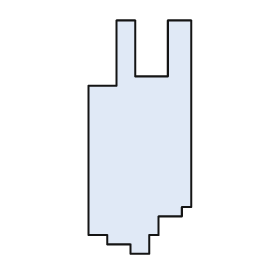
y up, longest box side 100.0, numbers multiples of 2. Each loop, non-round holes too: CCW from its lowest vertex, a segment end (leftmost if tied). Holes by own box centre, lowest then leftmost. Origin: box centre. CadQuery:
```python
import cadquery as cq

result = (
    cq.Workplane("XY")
    .moveTo(-4.0, -50.0)
    .lineTo(4.0, -50.0)
    .lineTo(4.0, -42.0)
    .lineTo(8.0, -42.0)
    .lineTo(8.0, -34.0)
    .lineTo(18.0, -34.0)
    .lineTo(18.0, -30.0)
    .lineTo(22.0, -30.0)
    .lineTo(22.0, 50.0)
    .lineTo(12.0, 50.0)
    .lineTo(12.0, 26.0)
    .lineTo(-2.0, 26.0)
    .lineTo(-2.0, 50.0)
    .lineTo(-10.0, 50.0)
    .lineTo(-10.0, 22.0)
    .lineTo(-22.0, 22.0)
    .lineTo(-22.0, -42.0)
    .lineTo(-14.0, -42.0)
    .lineTo(-14.0, -46.0)
    .lineTo(-4.0, -46.0)
    .close()
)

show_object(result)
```